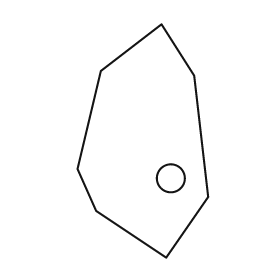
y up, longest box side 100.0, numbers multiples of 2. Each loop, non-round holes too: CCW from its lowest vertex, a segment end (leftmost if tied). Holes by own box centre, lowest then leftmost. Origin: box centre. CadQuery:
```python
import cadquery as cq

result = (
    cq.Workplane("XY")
    .moveTo(10.0, -50.0)
    .lineTo(28.0, -24.0)
    .lineTo(22.0, 28.0)
    .lineTo(8.0, 50.0)
    .lineTo(-18.0, 30.0)
    .lineTo(-28.0, -12.0)
    .lineTo(-20.0, -30.0)
    .close()
    .moveTo(12.0, -16.0)
    .circle(6.0)
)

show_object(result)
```